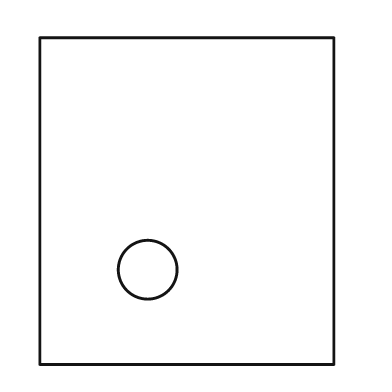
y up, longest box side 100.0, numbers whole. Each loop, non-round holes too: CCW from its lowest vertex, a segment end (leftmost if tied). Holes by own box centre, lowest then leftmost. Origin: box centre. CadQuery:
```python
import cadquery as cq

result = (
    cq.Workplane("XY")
    .moveTo(-45.0, -50.0)
    .lineTo(45.0, -50.0)
    .lineTo(45.0, 50.0)
    .lineTo(-45.0, 50.0)
    .close()
    .moveTo(-12.0, -21.0)
    .circle(9.0)
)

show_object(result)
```